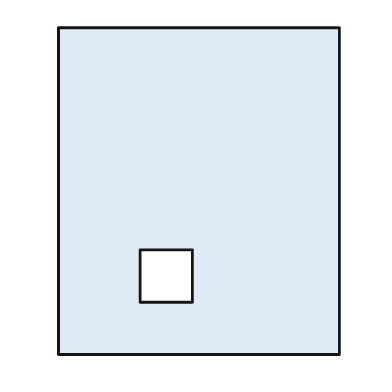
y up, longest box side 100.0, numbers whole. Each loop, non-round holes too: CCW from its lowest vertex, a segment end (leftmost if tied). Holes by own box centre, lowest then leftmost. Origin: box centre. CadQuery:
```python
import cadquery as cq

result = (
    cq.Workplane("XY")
    .moveTo(-43.0, -50.0)
    .lineTo(43.0, -50.0)
    .lineTo(43.0, 50.0)
    .lineTo(-43.0, 50.0)
    .close()
    .moveTo(-18.0, -34.0)
    .lineTo(-2.0, -34.0)
    .lineTo(-2.0, -18.0)
    .lineTo(-18.0, -18.0)
    .close()
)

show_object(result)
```